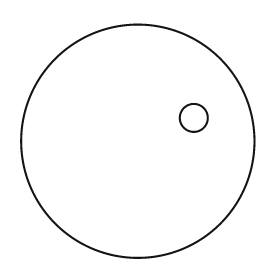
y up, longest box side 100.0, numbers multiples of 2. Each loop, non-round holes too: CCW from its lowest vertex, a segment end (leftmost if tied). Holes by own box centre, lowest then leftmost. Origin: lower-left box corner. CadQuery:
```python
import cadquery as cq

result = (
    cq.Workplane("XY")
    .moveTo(50.0, 50.0)
    .circle(50.0)
    .moveTo(74.0, 60.0)
    .circle(6.0)
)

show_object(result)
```